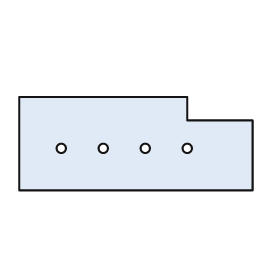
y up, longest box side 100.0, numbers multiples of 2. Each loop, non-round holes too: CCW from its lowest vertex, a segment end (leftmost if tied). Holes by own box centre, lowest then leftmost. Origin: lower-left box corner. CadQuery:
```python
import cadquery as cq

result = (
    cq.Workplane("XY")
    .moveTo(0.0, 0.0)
    .lineTo(100.0, 0.0)
    .lineTo(100.0, 30.0)
    .lineTo(72.0, 30.0)
    .lineTo(72.0, 40.0)
    .lineTo(0.0, 40.0)
    .close()
    .moveTo(18.0, 18.0)
    .circle(2.0)
    .moveTo(36.0, 18.0)
    .circle(2.0)
    .moveTo(54.0, 18.0)
    .circle(2.0)
    .moveTo(72.0, 18.0)
    .circle(2.0)
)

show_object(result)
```